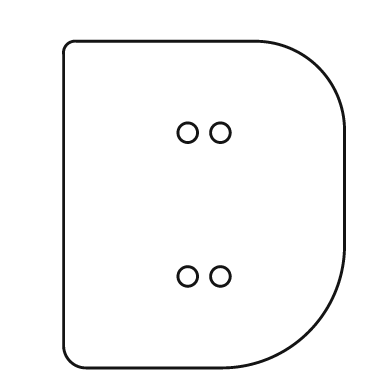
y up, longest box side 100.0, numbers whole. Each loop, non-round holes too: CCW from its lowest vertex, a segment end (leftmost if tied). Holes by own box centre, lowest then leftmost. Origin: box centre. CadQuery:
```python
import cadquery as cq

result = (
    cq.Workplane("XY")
    .moveTo(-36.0, -50.0)
    .lineTo(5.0, -50.0)
    .threePointArc((32.0, -39.0), (43.0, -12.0))
    .lineTo(43.0, 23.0)
    .threePointArc((35.0, 42.0), (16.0, 50.0))
    .lineTo(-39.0, 50.0)
    .threePointArc((-42.0, 49.0), (-43.0, 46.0))
    .lineTo(-43.0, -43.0)
    .threePointArc((-41.0, -48.0), (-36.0, -50.0))
    .close()
    .moveTo(-5.0, -22.0)
    .circle(3.0)
    .moveTo(5.0, -22.0)
    .circle(3.0)
    .moveTo(-5.0, 22.0)
    .circle(3.0)
    .moveTo(5.0, 22.0)
    .circle(3.0)
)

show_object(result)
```